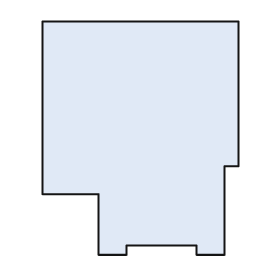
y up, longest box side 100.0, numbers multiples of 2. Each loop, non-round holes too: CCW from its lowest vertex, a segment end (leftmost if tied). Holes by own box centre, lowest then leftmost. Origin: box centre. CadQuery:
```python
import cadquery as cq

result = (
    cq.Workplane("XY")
    .moveTo(-18.0, -50.0)
    .lineTo(-6.0, -50.0)
    .lineTo(-6.0, -46.0)
    .lineTo(24.0, -46.0)
    .lineTo(24.0, -50.0)
    .lineTo(36.0, -50.0)
    .lineTo(36.0, -12.0)
    .lineTo(42.0, -12.0)
    .lineTo(42.0, 50.0)
    .lineTo(-42.0, 50.0)
    .lineTo(-42.0, -24.0)
    .lineTo(-18.0, -24.0)
    .close()
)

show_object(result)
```